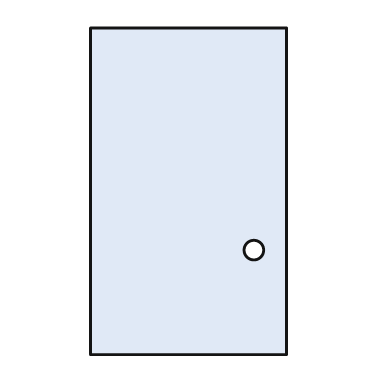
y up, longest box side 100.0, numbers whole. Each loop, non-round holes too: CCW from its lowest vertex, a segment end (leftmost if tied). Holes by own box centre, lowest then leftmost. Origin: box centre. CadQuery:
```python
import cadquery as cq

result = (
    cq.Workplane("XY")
    .moveTo(-30.0, -50.0)
    .lineTo(30.0, -50.0)
    .lineTo(30.0, 50.0)
    .lineTo(-30.0, 50.0)
    .close()
    .moveTo(20.0, -18.0)
    .circle(3.0)
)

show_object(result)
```